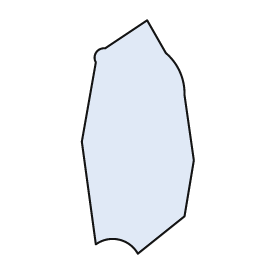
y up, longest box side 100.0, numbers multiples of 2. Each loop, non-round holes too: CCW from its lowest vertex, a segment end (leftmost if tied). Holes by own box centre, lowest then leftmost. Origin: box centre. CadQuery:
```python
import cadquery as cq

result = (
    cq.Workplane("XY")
    .moveTo(0.0, -50.0)
    .lineTo(20.0, -34.0)
    .lineTo(24.0, -10.0)
    .lineTo(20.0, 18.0)
    .threePointArc((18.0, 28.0), (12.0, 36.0))
    .lineTo(4.0, 50.0)
    .lineTo(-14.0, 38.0)
    .threePointArc((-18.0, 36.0), (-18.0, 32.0))
    .lineTo(-24.0, -2.0)
    .lineTo(-18.0, -46.0)
    .threePointArc((-8.0, -44.0), (0.0, -50.0))
    .close()
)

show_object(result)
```